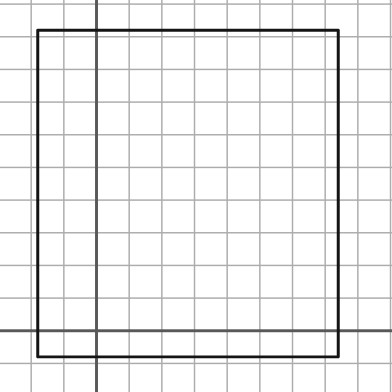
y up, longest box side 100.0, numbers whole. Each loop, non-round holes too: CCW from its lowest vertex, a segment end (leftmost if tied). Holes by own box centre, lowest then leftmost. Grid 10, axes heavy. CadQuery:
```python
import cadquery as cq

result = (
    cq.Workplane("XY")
    .moveTo(-18.0, -8.0)
    .lineTo(74.0, -8.0)
    .lineTo(74.0, 92.0)
    .lineTo(-18.0, 92.0)
    .close()
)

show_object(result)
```